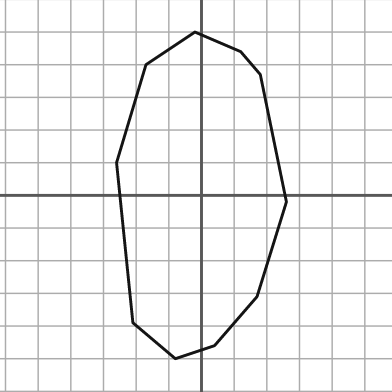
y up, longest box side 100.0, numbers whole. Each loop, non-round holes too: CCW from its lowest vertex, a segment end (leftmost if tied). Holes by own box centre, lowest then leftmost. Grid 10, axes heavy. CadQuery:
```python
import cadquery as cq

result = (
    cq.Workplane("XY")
    .moveTo(-8.0, -50.0)
    .lineTo(4.0, -46.0)
    .lineTo(17.0, -31.0)
    .lineTo(26.0, -2.0)
    .lineTo(18.0, 37.0)
    .lineTo(12.0, 44.0)
    .lineTo(-2.0, 50.0)
    .lineTo(-17.0, 40.0)
    .lineTo(-26.0, 10.0)
    .lineTo(-21.0, -39.0)
    .close()
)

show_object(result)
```